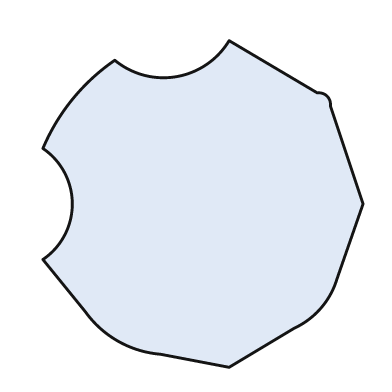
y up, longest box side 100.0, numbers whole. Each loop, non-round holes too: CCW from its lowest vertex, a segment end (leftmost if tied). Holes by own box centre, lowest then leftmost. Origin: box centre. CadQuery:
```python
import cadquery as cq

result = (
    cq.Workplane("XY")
    .moveTo(8.0, -50.0)
    .lineTo(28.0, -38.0)
    .threePointArc((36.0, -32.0), (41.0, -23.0))
    .lineTo(49.0, 0.0)
    .lineTo(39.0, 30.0)
    .threePointArc((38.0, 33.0), (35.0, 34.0))
    .lineTo(8.0, 50.0)
    .threePointArc((-8.0, 39.0), (-27.0, 44.0))
    .threePointArc((-40.0, 32.0), (-49.0, 17.0))
    .threePointArc((-40.0, 0.0), (-49.0, -17.0))
    .lineTo(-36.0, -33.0)
    .threePointArc((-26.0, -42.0), (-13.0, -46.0))
    .close()
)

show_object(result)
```